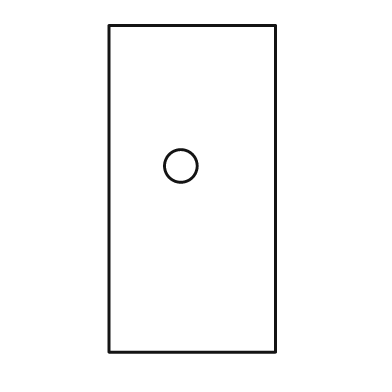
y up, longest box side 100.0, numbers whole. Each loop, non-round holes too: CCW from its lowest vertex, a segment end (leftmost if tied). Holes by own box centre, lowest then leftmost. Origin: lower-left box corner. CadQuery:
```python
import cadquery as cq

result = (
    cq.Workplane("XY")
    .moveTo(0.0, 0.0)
    .lineTo(51.0, 0.0)
    .lineTo(51.0, 100.0)
    .lineTo(0.0, 100.0)
    .close()
    .moveTo(22.0, 57.0)
    .circle(5.0)
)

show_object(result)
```